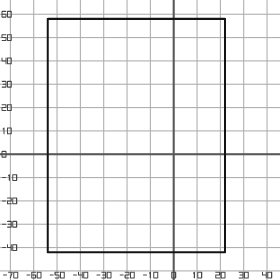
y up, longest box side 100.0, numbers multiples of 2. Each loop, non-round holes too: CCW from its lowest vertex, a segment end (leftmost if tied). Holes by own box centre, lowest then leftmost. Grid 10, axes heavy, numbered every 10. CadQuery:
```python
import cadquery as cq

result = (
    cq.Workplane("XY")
    .moveTo(-54.0, -42.0)
    .lineTo(22.0, -42.0)
    .lineTo(22.0, 58.0)
    .lineTo(-54.0, 58.0)
    .close()
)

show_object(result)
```